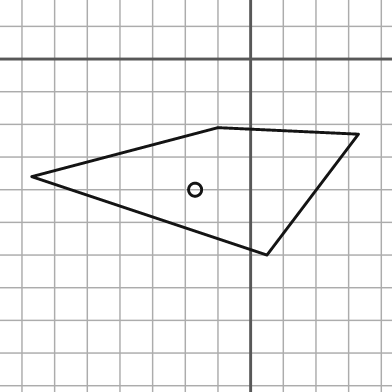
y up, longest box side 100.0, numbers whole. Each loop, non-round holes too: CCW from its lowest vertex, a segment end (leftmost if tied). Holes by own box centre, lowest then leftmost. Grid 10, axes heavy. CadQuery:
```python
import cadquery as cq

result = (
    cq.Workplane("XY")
    .moveTo(5.0, -60.0)
    .lineTo(33.0, -23.0)
    .lineTo(-10.0, -21.0)
    .lineTo(-67.0, -36.0)
    .close()
    .moveTo(-17.0, -40.0)
    .circle(2.0)
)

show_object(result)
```